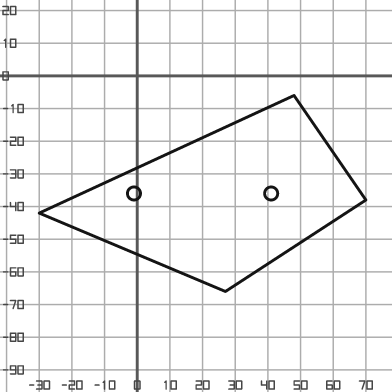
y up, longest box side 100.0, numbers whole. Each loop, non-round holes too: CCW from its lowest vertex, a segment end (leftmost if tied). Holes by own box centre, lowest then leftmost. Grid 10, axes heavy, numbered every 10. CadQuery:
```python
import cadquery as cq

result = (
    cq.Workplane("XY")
    .moveTo(27.0, -66.0)
    .lineTo(70.0, -38.0)
    .lineTo(48.0, -6.0)
    .lineTo(-30.0, -42.0)
    .close()
    .moveTo(-1.0, -36.0)
    .circle(2.0)
    .moveTo(41.0, -36.0)
    .circle(2.0)
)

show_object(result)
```